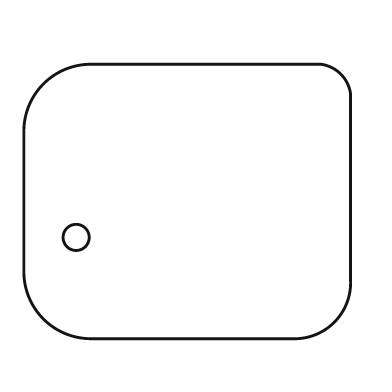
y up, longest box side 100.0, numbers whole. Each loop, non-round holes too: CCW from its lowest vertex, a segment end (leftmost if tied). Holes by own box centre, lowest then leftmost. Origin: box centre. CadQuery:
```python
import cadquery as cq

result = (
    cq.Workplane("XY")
    .moveTo(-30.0, -42.0)
    .lineTo(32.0, -42.0)
    .threePointArc((45.0, -37.0), (50.0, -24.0))
    .lineTo(50.0, 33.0)
    .threePointArc((47.0, 39.0), (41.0, 42.0))
    .lineTo(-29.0, 42.0)
    .threePointArc((-44.0, 36.0), (-50.0, 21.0))
    .lineTo(-50.0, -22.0)
    .threePointArc((-44.0, -36.0), (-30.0, -42.0))
    .close()
    .moveTo(-34.0, -11.0)
    .circle(4.0)
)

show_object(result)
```